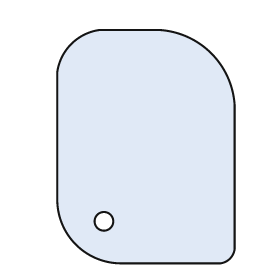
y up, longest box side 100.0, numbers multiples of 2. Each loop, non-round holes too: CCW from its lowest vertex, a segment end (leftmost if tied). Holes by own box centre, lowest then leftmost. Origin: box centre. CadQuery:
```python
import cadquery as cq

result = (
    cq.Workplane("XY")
    .moveTo(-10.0, -50.0)
    .lineTo(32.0, -50.0)
    .threePointArc((36.0, -48.0), (38.0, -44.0))
    .lineTo(38.0, 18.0)
    .threePointArc((28.0, 40.0), (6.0, 50.0))
    .lineTo(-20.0, 50.0)
    .threePointArc((-32.0, 44.0), (-38.0, 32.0))
    .lineTo(-38.0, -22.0)
    .threePointArc((-30.0, -42.0), (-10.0, -50.0))
    .close()
    .moveTo(-18.0, -32.0)
    .circle(4.0)
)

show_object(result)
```